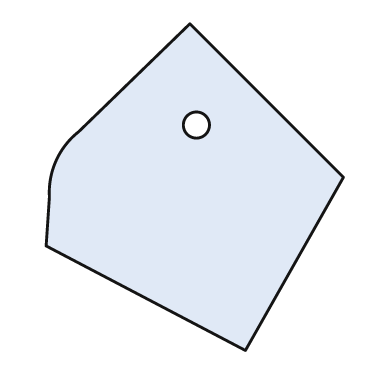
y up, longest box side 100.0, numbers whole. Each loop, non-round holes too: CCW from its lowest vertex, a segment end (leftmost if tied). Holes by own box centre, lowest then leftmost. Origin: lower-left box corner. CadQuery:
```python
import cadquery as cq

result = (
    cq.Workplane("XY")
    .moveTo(61.0, 0.0)
    .lineTo(91.0, 53.0)
    .lineTo(44.0, 100.0)
    .lineTo(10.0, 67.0)
    .threePointArc((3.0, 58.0), (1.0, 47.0))
    .lineTo(0.0, 32.0)
    .close()
    .moveTo(46.0, 69.0)
    .circle(4.0)
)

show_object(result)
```